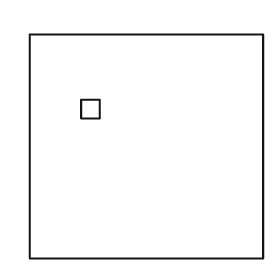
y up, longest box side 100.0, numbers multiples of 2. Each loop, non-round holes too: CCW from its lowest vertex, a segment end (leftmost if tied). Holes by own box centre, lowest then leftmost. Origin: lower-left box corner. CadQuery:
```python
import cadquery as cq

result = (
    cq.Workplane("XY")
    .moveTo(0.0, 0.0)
    .lineTo(100.0, 0.0)
    .lineTo(100.0, 96.0)
    .lineTo(0.0, 96.0)
    .close()
    .moveTo(22.0, 60.0)
    .lineTo(30.0, 60.0)
    .lineTo(30.0, 68.0)
    .lineTo(22.0, 68.0)
    .close()
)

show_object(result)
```